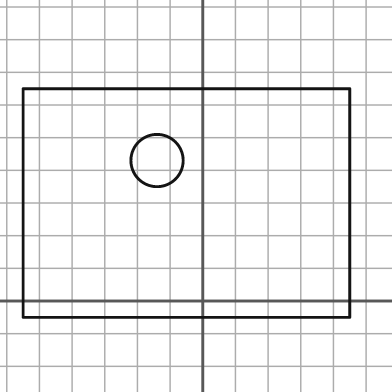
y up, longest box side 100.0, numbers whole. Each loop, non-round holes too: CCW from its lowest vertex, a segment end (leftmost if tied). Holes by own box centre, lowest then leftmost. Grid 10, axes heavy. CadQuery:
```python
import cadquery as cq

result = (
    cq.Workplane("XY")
    .moveTo(-55.0, -5.0)
    .lineTo(45.0, -5.0)
    .lineTo(45.0, 65.0)
    .lineTo(-55.0, 65.0)
    .close()
    .moveTo(-14.0, 43.0)
    .circle(8.0)
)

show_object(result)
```